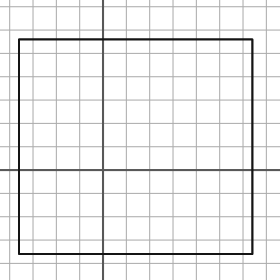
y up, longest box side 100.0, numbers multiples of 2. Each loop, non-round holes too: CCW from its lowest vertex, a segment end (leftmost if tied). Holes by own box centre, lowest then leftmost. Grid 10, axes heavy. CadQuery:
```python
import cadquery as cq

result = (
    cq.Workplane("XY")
    .moveTo(-36.0, -36.0)
    .lineTo(64.0, -36.0)
    .lineTo(64.0, 56.0)
    .lineTo(-36.0, 56.0)
    .close()
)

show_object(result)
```